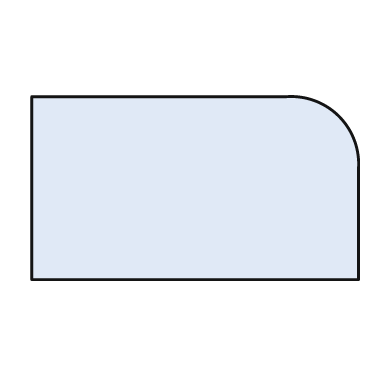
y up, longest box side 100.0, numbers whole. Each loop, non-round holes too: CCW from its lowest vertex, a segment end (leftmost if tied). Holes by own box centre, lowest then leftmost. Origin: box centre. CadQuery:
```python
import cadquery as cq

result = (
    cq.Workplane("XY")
    .moveTo(-50.0, -28.0)
    .lineTo(50.0, -28.0)
    .lineTo(50.0, 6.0)
    .threePointArc((44.0, 22.0), (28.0, 28.0))
    .lineTo(-50.0, 28.0)
    .close()
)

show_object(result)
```